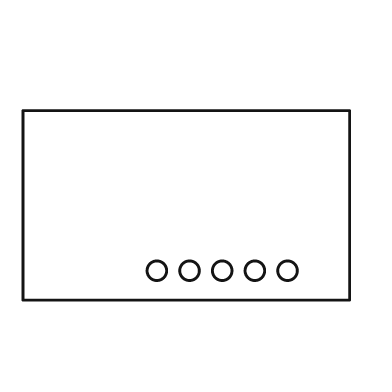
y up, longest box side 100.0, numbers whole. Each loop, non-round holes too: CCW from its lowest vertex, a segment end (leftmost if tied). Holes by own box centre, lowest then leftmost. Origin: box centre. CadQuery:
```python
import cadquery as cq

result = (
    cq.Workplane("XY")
    .moveTo(-50.0, -29.0)
    .lineTo(50.0, -29.0)
    .lineTo(50.0, 29.0)
    .lineTo(-50.0, 29.0)
    .close()
    .moveTo(-9.0, -20.0)
    .circle(3.0)
    .moveTo(1.0, -20.0)
    .circle(3.0)
    .moveTo(11.0, -20.0)
    .circle(3.0)
    .moveTo(21.0, -20.0)
    .circle(3.0)
    .moveTo(31.0, -20.0)
    .circle(3.0)
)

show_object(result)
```